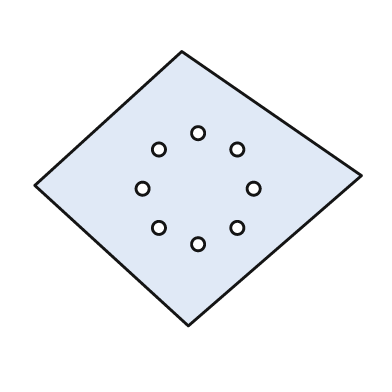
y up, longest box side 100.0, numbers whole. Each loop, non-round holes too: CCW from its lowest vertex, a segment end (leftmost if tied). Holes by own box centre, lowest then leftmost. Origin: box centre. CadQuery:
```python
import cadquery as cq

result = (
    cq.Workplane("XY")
    .moveTo(-3.0, -42.0)
    .lineTo(50.0, 4.0)
    .lineTo(-5.0, 42.0)
    .lineTo(-50.0, 1.0)
    .close()
    .moveTo(0.0, -17.0)
    .circle(2.0)
    .moveTo(-12.0, -12.0)
    .circle(2.0)
    .moveTo(12.0, -12.0)
    .circle(2.0)
    .moveTo(-17.0, 0.0)
    .circle(2.0)
    .moveTo(17.0, 0.0)
    .circle(2.0)
    .moveTo(-12.0, 12.0)
    .circle(2.0)
    .moveTo(12.0, 12.0)
    .circle(2.0)
    .moveTo(0.0, 17.0)
    .circle(2.0)
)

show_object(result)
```